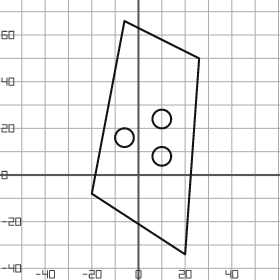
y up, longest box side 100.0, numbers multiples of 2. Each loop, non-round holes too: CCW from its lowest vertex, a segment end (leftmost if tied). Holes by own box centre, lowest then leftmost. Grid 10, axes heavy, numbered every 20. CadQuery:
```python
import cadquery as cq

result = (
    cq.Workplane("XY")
    .moveTo(20.0, -34.0)
    .lineTo(26.0, 50.0)
    .lineTo(-6.0, 66.0)
    .lineTo(-20.0, -8.0)
    .close()
    .moveTo(10.0, 8.0)
    .circle(4.0)
    .moveTo(-6.0, 16.0)
    .circle(4.0)
    .moveTo(10.0, 24.0)
    .circle(4.0)
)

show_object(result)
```